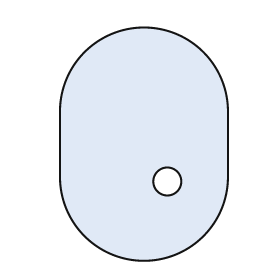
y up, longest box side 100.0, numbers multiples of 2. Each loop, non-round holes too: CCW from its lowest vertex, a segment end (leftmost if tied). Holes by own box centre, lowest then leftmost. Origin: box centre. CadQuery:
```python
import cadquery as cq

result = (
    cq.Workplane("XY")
    .moveTo(-36.0, -14.0)
    .threePointArc((0.0, -50.0), (36.0, -14.0))
    .lineTo(36.0, 14.0)
    .threePointArc((0.0, 50.0), (-36.0, 14.0))
    .close()
    .moveTo(10.0, -16.0)
    .circle(6.0)
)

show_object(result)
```